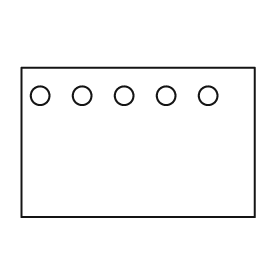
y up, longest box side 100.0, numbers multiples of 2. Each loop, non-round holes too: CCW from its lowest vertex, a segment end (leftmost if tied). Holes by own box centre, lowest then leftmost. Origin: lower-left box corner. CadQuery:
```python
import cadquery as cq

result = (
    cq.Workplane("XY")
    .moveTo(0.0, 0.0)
    .lineTo(100.0, 0.0)
    .lineTo(100.0, 64.0)
    .lineTo(0.0, 64.0)
    .close()
    .moveTo(8.0, 52.0)
    .circle(4.0)
    .moveTo(26.0, 52.0)
    .circle(4.0)
    .moveTo(44.0, 52.0)
    .circle(4.0)
    .moveTo(62.0, 52.0)
    .circle(4.0)
    .moveTo(80.0, 52.0)
    .circle(4.0)
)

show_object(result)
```